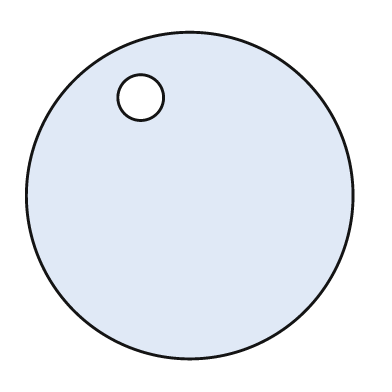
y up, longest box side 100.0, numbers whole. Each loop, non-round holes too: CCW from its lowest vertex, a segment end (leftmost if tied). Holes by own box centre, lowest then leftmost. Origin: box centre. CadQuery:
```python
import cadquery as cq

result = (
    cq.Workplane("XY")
    .moveTo(0.0, 0.0)
    .circle(50.0)
    .moveTo(-15.0, 30.0)
    .circle(7.0)
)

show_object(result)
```